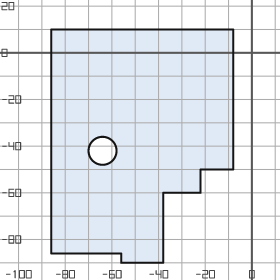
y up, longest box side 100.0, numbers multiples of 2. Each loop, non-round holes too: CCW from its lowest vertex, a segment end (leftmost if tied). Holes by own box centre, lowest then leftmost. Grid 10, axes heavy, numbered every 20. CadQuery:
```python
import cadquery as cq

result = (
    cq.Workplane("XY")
    .moveTo(-56.0, -90.0)
    .lineTo(-38.0, -90.0)
    .lineTo(-38.0, -60.0)
    .lineTo(-22.0, -60.0)
    .lineTo(-22.0, -50.0)
    .lineTo(-8.0, -50.0)
    .lineTo(-8.0, 10.0)
    .lineTo(-86.0, 10.0)
    .lineTo(-86.0, -86.0)
    .lineTo(-56.0, -86.0)
    .close()
    .moveTo(-64.0, -42.0)
    .circle(6.0)
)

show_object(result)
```